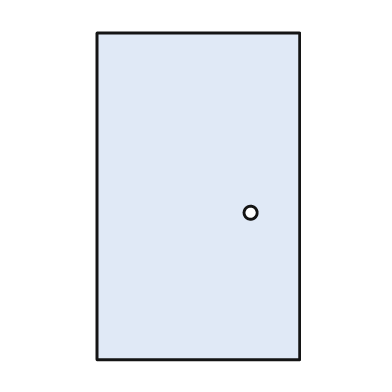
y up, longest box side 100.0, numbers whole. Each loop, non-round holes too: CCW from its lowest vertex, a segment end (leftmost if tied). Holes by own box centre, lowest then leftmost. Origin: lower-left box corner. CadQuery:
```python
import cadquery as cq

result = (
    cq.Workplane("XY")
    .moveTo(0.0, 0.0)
    .lineTo(62.0, 0.0)
    .lineTo(62.0, 100.0)
    .lineTo(0.0, 100.0)
    .close()
    .moveTo(47.0, 45.0)
    .circle(2.0)
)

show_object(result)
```